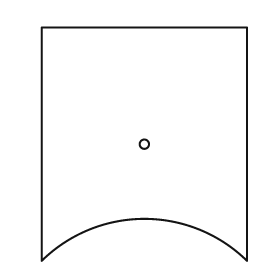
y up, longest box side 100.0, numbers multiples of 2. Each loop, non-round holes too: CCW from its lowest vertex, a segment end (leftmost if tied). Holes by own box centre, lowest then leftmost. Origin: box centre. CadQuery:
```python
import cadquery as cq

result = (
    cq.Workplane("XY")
    .moveTo(-44.0, -50.0)
    .threePointArc((0.0, -32.0), (44.0, -50.0))
    .lineTo(44.0, 50.0)
    .lineTo(-44.0, 50.0)
    .close()
    .moveTo(0.0, 0.0)
    .circle(2.0)
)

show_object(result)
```